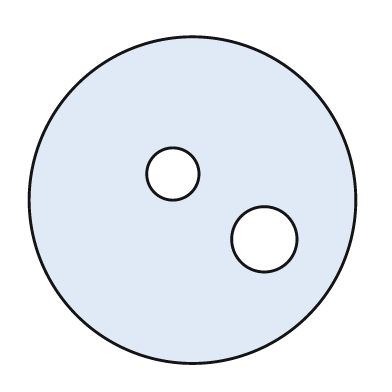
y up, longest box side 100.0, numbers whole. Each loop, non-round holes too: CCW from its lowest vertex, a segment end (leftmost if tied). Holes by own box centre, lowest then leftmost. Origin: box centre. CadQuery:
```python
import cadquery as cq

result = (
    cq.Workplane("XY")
    .moveTo(0.0, 0.0)
    .circle(50.0)
    .moveTo(22.0, -12.0)
    .circle(10.0)
    .moveTo(-6.0, 8.0)
    .circle(8.0)
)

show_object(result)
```